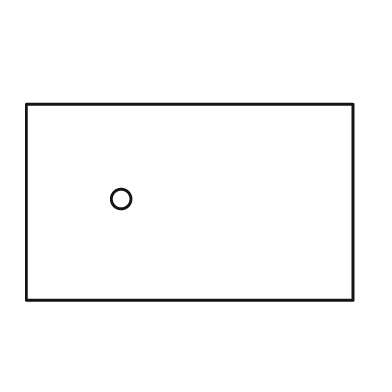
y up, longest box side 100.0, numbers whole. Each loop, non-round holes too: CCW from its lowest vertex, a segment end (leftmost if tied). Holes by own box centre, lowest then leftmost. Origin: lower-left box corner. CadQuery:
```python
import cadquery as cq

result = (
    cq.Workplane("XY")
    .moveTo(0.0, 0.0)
    .lineTo(100.0, 0.0)
    .lineTo(100.0, 60.0)
    .lineTo(0.0, 60.0)
    .close()
    .moveTo(29.0, 31.0)
    .circle(3.0)
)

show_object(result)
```